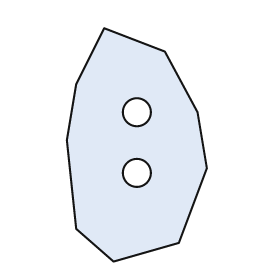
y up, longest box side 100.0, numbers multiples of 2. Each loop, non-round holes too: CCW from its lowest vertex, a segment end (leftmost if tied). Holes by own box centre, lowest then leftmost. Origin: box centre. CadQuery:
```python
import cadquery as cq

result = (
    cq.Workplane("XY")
    .moveTo(-10.0, -50.0)
    .lineTo(18.0, -42.0)
    .lineTo(30.0, -10.0)
    .lineTo(26.0, 14.0)
    .lineTo(12.0, 40.0)
    .lineTo(-14.0, 50.0)
    .lineTo(-26.0, 26.0)
    .lineTo(-30.0, 2.0)
    .lineTo(-26.0, -36.0)
    .close()
    .moveTo(0.0, -12.0)
    .circle(6.0)
    .moveTo(0.0, 14.0)
    .circle(6.0)
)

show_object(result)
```